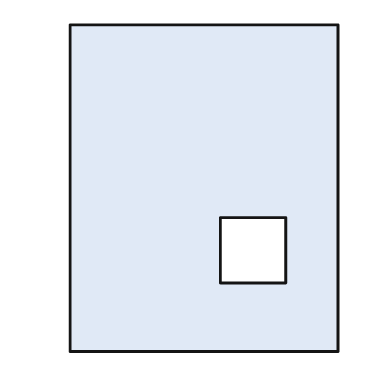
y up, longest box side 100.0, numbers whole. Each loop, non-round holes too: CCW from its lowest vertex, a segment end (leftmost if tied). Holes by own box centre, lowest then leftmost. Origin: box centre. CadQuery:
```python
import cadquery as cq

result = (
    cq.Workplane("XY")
    .moveTo(-41.0, -50.0)
    .lineTo(41.0, -50.0)
    .lineTo(41.0, 50.0)
    .lineTo(-41.0, 50.0)
    .close()
    .moveTo(5.0, -29.0)
    .lineTo(25.0, -29.0)
    .lineTo(25.0, -9.0)
    .lineTo(5.0, -9.0)
    .close()
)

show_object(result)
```